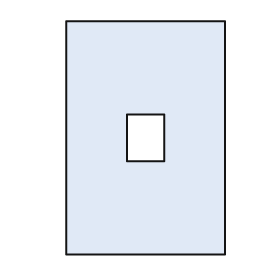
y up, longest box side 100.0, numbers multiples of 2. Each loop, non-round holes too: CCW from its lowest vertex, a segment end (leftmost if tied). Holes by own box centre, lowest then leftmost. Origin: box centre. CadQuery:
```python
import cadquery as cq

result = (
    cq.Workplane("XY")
    .moveTo(-34.0, -50.0)
    .lineTo(34.0, -50.0)
    .lineTo(34.0, 50.0)
    .lineTo(-34.0, 50.0)
    .close()
    .moveTo(-8.0, -10.0)
    .lineTo(8.0, -10.0)
    .lineTo(8.0, 10.0)
    .lineTo(-8.0, 10.0)
    .close()
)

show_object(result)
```